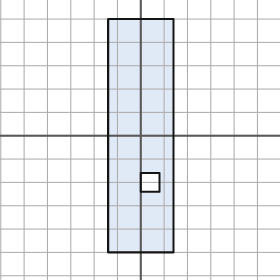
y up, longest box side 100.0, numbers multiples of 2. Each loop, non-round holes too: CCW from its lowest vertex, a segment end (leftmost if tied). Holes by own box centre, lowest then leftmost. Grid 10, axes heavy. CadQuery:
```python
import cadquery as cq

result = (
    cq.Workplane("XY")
    .moveTo(-14.0, -50.0)
    .lineTo(14.0, -50.0)
    .lineTo(14.0, 50.0)
    .lineTo(-14.0, 50.0)
    .close()
    .moveTo(0.0, -24.0)
    .lineTo(8.0, -24.0)
    .lineTo(8.0, -16.0)
    .lineTo(0.0, -16.0)
    .close()
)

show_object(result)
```